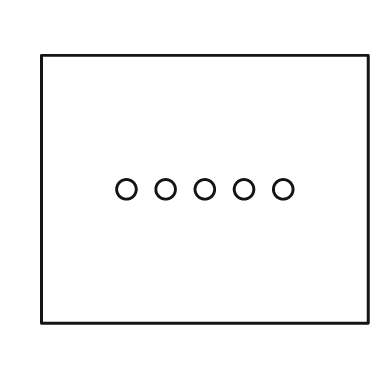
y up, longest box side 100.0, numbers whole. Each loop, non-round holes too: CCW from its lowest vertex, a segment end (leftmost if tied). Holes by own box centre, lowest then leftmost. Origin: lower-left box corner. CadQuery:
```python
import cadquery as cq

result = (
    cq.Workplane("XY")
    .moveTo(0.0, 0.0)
    .lineTo(100.0, 0.0)
    .lineTo(100.0, 82.0)
    .lineTo(0.0, 82.0)
    .close()
    .moveTo(26.0, 41.0)
    .circle(3.0)
    .moveTo(38.0, 41.0)
    .circle(3.0)
    .moveTo(50.0, 41.0)
    .circle(3.0)
    .moveTo(62.0, 41.0)
    .circle(3.0)
    .moveTo(74.0, 41.0)
    .circle(3.0)
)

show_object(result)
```